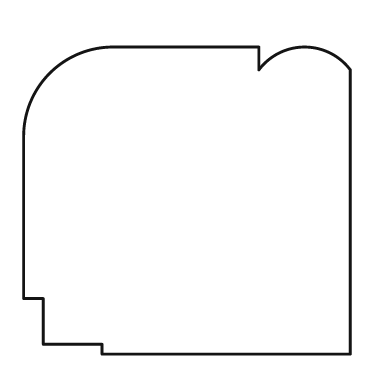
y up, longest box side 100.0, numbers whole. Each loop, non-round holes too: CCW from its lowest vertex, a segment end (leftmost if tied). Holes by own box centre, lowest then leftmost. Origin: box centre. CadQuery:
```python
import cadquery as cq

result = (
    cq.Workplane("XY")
    .moveTo(-26.0, -47.0)
    .lineTo(50.0, -47.0)
    .lineTo(50.0, 40.0)
    .threePointArc((36.0, 47.0), (22.0, 40.0))
    .lineTo(22.0, 47.0)
    .lineTo(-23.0, 47.0)
    .threePointArc((-42.0, 39.0), (-50.0, 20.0))
    .lineTo(-50.0, -30.0)
    .lineTo(-44.0, -30.0)
    .lineTo(-44.0, -44.0)
    .lineTo(-26.0, -44.0)
    .close()
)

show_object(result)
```